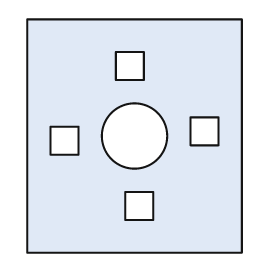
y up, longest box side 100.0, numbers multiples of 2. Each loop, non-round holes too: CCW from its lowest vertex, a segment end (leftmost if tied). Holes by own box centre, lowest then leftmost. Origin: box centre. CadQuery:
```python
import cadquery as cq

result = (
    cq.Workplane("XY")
    .moveTo(-46.0, -50.0)
    .lineTo(46.0, -50.0)
    .lineTo(46.0, 50.0)
    .lineTo(-46.0, 50.0)
    .close()
    .moveTo(-4.0, -36.0)
    .lineTo(8.0, -36.0)
    .lineTo(8.0, -24.0)
    .lineTo(-4.0, -24.0)
    .close()
    .moveTo(-36.0, -8.0)
    .lineTo(-24.0, -8.0)
    .lineTo(-24.0, 4.0)
    .lineTo(-36.0, 4.0)
    .close()
    .moveTo(0.0, 0.0)
    .circle(14.0)
    .moveTo(24.0, -4.0)
    .lineTo(36.0, -4.0)
    .lineTo(36.0, 8.0)
    .lineTo(24.0, 8.0)
    .close()
    .moveTo(-8.0, 24.0)
    .lineTo(4.0, 24.0)
    .lineTo(4.0, 36.0)
    .lineTo(-8.0, 36.0)
    .close()
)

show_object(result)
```